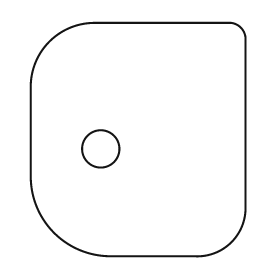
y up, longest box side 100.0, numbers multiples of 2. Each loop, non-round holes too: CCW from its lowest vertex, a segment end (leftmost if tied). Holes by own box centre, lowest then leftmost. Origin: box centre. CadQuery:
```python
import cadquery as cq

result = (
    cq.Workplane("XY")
    .moveTo(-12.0, -50.0)
    .lineTo(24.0, -50.0)
    .threePointArc((40.0, -44.0), (46.0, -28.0))
    .lineTo(46.0, 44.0)
    .threePointArc((44.0, 48.0), (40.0, 50.0))
    .lineTo(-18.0, 50.0)
    .threePointArc((-38.0, 42.0), (-46.0, 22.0))
    .lineTo(-46.0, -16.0)
    .threePointArc((-36.0, -40.0), (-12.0, -50.0))
    .close()
    .moveTo(-16.0, -4.0)
    .circle(8.0)
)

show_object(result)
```